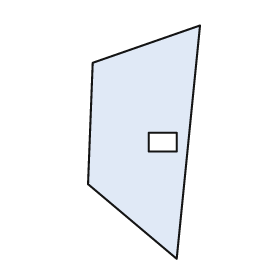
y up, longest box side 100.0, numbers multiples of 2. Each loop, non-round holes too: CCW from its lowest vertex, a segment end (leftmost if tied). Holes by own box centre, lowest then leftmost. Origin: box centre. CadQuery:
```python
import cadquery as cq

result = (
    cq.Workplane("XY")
    .moveTo(14.0, -50.0)
    .lineTo(24.0, 50.0)
    .lineTo(-22.0, 34.0)
    .lineTo(-24.0, -18.0)
    .close()
    .moveTo(2.0, -4.0)
    .lineTo(14.0, -4.0)
    .lineTo(14.0, 4.0)
    .lineTo(2.0, 4.0)
    .close()
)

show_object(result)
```